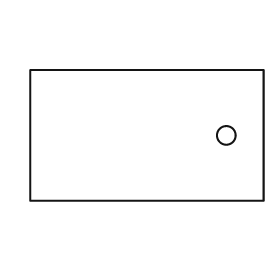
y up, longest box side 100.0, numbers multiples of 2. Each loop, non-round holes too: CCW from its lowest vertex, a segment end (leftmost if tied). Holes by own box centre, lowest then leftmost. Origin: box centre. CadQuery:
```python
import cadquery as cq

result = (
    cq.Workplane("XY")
    .moveTo(-50.0, -28.0)
    .lineTo(50.0, -28.0)
    .lineTo(50.0, 28.0)
    .lineTo(-50.0, 28.0)
    .close()
    .moveTo(34.0, 0.0)
    .circle(4.0)
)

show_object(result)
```